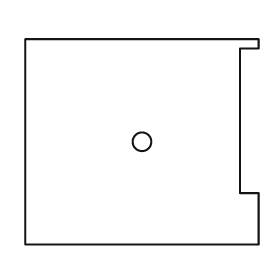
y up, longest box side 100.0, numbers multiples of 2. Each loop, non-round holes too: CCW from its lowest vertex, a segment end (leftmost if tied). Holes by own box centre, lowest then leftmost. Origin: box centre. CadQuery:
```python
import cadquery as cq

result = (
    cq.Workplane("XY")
    .moveTo(-50.0, -44.0)
    .lineTo(50.0, -44.0)
    .lineTo(50.0, -22.0)
    .lineTo(42.0, -22.0)
    .lineTo(42.0, 40.0)
    .lineTo(50.0, 40.0)
    .lineTo(50.0, 44.0)
    .lineTo(-50.0, 44.0)
    .close()
    .moveTo(0.0, 0.0)
    .circle(4.0)
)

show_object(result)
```